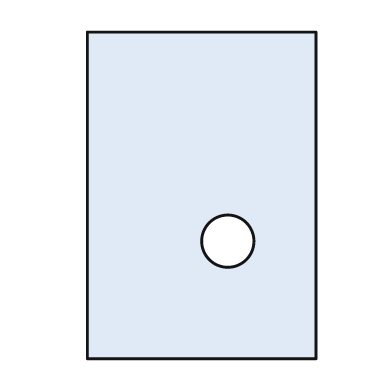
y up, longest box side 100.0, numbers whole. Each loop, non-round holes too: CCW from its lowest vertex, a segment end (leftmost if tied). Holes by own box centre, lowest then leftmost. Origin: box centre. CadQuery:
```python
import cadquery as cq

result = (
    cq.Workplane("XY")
    .moveTo(-35.0, -50.0)
    .lineTo(35.0, -50.0)
    .lineTo(35.0, 50.0)
    .lineTo(-35.0, 50.0)
    .close()
    .moveTo(8.0, -14.0)
    .circle(8.0)
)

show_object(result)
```